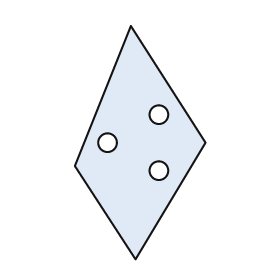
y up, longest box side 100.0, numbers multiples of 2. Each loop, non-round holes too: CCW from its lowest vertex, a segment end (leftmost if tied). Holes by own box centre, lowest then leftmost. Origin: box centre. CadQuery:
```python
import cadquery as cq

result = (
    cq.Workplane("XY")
    .moveTo(-2.0, -50.0)
    .lineTo(28.0, 0.0)
    .lineTo(-4.0, 50.0)
    .lineTo(-28.0, -10.0)
    .close()
    .moveTo(8.0, -12.0)
    .circle(4.0)
    .moveTo(-14.0, 0.0)
    .circle(4.0)
    .moveTo(8.0, 12.0)
    .circle(4.0)
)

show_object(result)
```